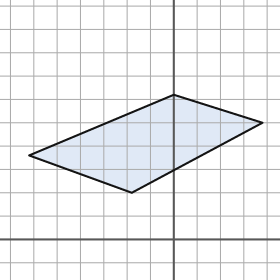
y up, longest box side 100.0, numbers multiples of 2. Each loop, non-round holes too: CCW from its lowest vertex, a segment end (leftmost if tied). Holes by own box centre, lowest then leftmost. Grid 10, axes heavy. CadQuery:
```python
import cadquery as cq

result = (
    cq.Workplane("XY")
    .moveTo(-18.0, 20.0)
    .lineTo(38.0, 50.0)
    .lineTo(0.0, 62.0)
    .lineTo(-62.0, 36.0)
    .close()
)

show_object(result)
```